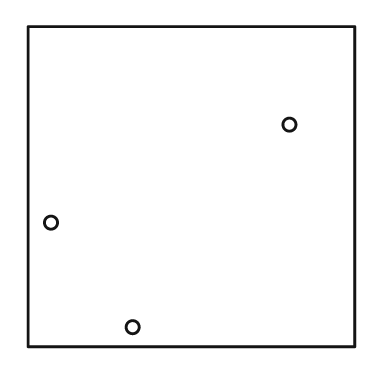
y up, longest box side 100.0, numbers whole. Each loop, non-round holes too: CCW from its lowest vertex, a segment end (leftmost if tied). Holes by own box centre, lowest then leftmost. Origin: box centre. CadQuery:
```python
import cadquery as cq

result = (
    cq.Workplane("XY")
    .moveTo(-50.0, -49.0)
    .lineTo(50.0, -49.0)
    .lineTo(50.0, 49.0)
    .lineTo(-50.0, 49.0)
    .close()
    .moveTo(-18.0, -43.0)
    .circle(2.0)
    .moveTo(-43.0, -11.0)
    .circle(2.0)
    .moveTo(30.0, 19.0)
    .circle(2.0)
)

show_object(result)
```